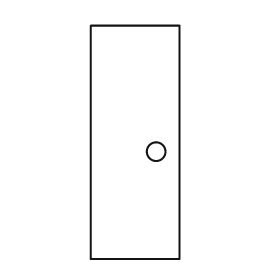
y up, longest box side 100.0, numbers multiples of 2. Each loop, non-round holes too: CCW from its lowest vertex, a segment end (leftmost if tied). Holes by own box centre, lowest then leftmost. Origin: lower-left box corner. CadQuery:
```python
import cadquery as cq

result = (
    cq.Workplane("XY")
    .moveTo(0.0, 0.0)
    .lineTo(38.0, 0.0)
    .lineTo(38.0, 100.0)
    .lineTo(0.0, 100.0)
    .close()
    .moveTo(28.0, 46.0)
    .circle(4.0)
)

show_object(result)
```